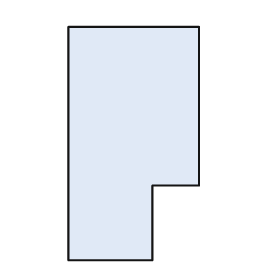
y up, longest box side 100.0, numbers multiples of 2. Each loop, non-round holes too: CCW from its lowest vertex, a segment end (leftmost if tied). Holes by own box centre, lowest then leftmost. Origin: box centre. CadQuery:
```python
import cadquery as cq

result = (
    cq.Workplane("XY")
    .moveTo(-28.0, -50.0)
    .lineTo(8.0, -50.0)
    .lineTo(8.0, -18.0)
    .lineTo(28.0, -18.0)
    .lineTo(28.0, 50.0)
    .lineTo(-28.0, 50.0)
    .close()
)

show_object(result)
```